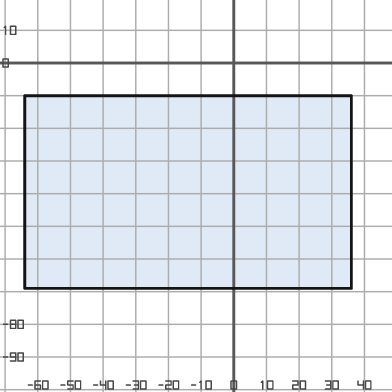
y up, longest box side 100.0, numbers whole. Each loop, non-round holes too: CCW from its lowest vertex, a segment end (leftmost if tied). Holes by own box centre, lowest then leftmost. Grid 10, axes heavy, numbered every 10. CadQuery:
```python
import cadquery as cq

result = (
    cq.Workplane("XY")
    .moveTo(-64.0, -69.0)
    .lineTo(36.0, -69.0)
    .lineTo(36.0, -10.0)
    .lineTo(-64.0, -10.0)
    .close()
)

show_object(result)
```